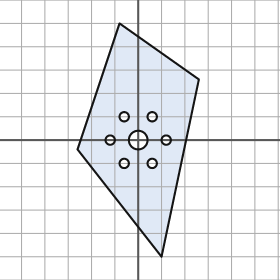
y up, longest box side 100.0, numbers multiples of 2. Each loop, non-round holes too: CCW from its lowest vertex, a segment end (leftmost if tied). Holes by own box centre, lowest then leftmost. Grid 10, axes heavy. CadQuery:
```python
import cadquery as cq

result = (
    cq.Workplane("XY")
    .moveTo(10.0, -50.0)
    .lineTo(26.0, 26.0)
    .lineTo(-8.0, 50.0)
    .lineTo(-26.0, -4.0)
    .close()
    .moveTo(-6.0, -10.0)
    .circle(2.0)
    .moveTo(6.0, -10.0)
    .circle(2.0)
    .moveTo(-12.0, 0.0)
    .circle(2.0)
    .moveTo(0.0, 0.0)
    .circle(4.0)
    .moveTo(12.0, 0.0)
    .circle(2.0)
    .moveTo(-6.0, 10.0)
    .circle(2.0)
    .moveTo(6.0, 10.0)
    .circle(2.0)
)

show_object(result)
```